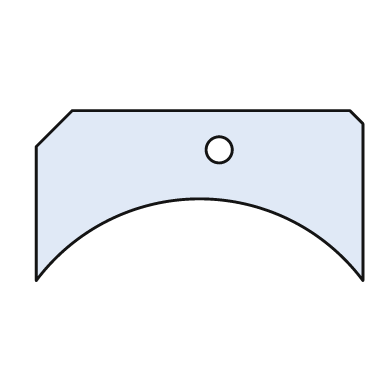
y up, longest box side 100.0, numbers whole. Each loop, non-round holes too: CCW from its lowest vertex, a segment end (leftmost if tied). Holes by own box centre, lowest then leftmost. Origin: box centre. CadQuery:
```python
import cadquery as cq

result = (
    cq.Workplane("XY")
    .moveTo(-50.0, -26.0)
    .threePointArc((0.0, -1.0), (50.0, -26.0))
    .lineTo(50.0, 22.0)
    .lineTo(46.0, 26.0)
    .lineTo(-39.0, 26.0)
    .lineTo(-50.0, 15.0)
    .close()
    .moveTo(6.0, 14.0)
    .circle(4.0)
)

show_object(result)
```